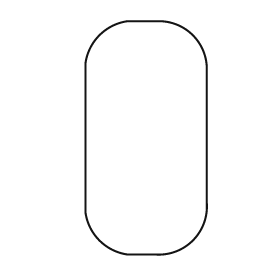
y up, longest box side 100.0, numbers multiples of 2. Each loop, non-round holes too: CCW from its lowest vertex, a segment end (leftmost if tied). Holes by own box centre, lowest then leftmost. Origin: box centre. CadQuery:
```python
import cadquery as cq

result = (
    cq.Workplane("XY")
    .moveTo(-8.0, -50.0)
    .lineTo(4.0, -50.0)
    .threePointArc((20.0, -44.0), (26.0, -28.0))
    .lineTo(26.0, 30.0)
    .threePointArc((20.0, 44.0), (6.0, 50.0))
    .lineTo(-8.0, 50.0)
    .threePointArc((-20.0, 44.0), (-26.0, 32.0))
    .lineTo(-26.0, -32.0)
    .threePointArc((-20.0, -44.0), (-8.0, -50.0))
    .close()
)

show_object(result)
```